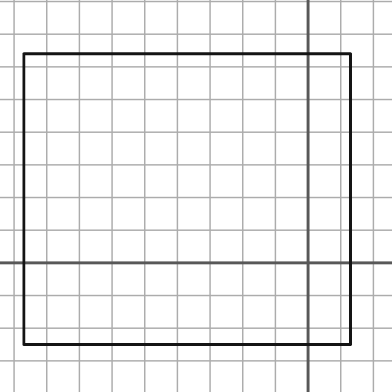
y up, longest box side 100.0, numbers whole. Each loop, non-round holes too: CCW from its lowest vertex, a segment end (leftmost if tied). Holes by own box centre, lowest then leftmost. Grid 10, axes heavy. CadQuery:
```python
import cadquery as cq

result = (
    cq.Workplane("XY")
    .moveTo(-87.0, -25.0)
    .lineTo(13.0, -25.0)
    .lineTo(13.0, 64.0)
    .lineTo(-87.0, 64.0)
    .close()
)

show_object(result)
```